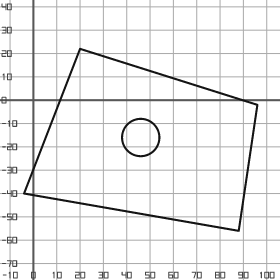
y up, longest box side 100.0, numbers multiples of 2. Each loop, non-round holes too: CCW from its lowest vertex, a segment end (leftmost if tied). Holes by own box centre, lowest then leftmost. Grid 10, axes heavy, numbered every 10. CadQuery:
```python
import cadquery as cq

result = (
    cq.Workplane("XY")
    .moveTo(88.0, -56.0)
    .lineTo(96.0, -2.0)
    .lineTo(20.0, 22.0)
    .lineTo(-4.0, -40.0)
    .close()
    .moveTo(46.0, -16.0)
    .circle(8.0)
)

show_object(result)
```